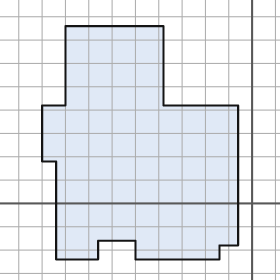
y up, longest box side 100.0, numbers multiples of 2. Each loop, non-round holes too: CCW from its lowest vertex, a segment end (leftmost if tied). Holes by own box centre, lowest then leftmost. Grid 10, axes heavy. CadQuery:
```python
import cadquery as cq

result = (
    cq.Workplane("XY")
    .moveTo(-84.0, -24.0)
    .lineTo(-66.0, -24.0)
    .lineTo(-66.0, -16.0)
    .lineTo(-50.0, -16.0)
    .lineTo(-50.0, -24.0)
    .lineTo(-14.0, -24.0)
    .lineTo(-14.0, -18.0)
    .lineTo(-6.0, -18.0)
    .lineTo(-6.0, 42.0)
    .lineTo(-38.0, 42.0)
    .lineTo(-38.0, 76.0)
    .lineTo(-80.0, 76.0)
    .lineTo(-80.0, 42.0)
    .lineTo(-90.0, 42.0)
    .lineTo(-90.0, 18.0)
    .lineTo(-84.0, 18.0)
    .close()
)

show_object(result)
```